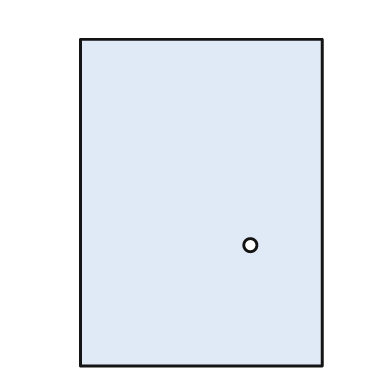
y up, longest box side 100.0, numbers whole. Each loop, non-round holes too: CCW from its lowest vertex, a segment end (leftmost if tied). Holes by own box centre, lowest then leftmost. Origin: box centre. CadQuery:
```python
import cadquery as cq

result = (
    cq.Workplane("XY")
    .moveTo(-37.0, -50.0)
    .lineTo(37.0, -50.0)
    .lineTo(37.0, 50.0)
    .lineTo(-37.0, 50.0)
    .close()
    .moveTo(15.0, -13.0)
    .circle(2.0)
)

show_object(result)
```